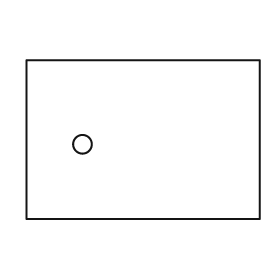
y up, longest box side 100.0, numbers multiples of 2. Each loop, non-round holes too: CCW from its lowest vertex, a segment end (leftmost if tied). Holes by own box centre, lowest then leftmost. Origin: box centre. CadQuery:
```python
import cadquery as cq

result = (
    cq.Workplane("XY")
    .moveTo(-50.0, -34.0)
    .lineTo(50.0, -34.0)
    .lineTo(50.0, 34.0)
    .lineTo(-50.0, 34.0)
    .close()
    .moveTo(-26.0, -2.0)
    .circle(4.0)
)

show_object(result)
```